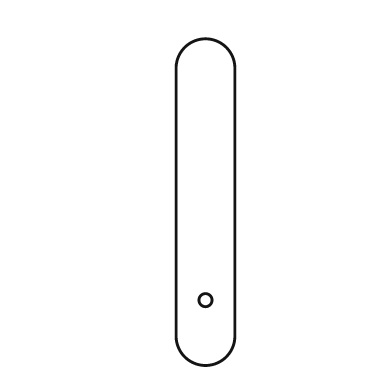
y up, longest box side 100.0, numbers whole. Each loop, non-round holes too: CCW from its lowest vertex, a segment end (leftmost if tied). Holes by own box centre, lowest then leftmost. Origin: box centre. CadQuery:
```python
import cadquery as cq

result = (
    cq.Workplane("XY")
    .moveTo(-9.0, -41.0)
    .threePointArc((0.0, -50.0), (9.0, -41.0))
    .lineTo(9.0, 41.0)
    .threePointArc((0.0, 50.0), (-9.0, 41.0))
    .close()
    .moveTo(0.0, -30.0)
    .circle(2.0)
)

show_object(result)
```